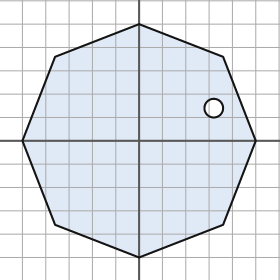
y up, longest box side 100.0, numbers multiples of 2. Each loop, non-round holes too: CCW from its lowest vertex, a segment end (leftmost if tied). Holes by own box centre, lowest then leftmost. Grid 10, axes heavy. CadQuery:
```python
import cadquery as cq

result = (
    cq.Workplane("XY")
    .moveTo(0.0, -50.0)
    .lineTo(36.0, -36.0)
    .lineTo(50.0, 0.0)
    .lineTo(36.0, 36.0)
    .lineTo(0.0, 50.0)
    .lineTo(-36.0, 36.0)
    .lineTo(-50.0, 0.0)
    .lineTo(-36.0, -36.0)
    .close()
    .moveTo(32.0, 14.0)
    .circle(4.0)
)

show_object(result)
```